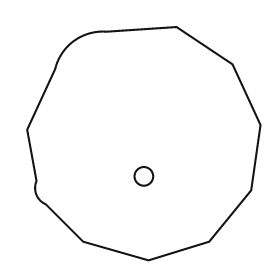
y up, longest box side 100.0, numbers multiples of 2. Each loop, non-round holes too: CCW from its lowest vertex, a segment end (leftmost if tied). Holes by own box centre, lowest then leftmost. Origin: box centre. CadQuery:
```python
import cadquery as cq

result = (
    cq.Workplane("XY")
    .moveTo(2.0, -50.0)
    .lineTo(28.0, -42.0)
    .lineTo(46.0, -20.0)
    .lineTo(50.0, 8.0)
    .lineTo(38.0, 34.0)
    .lineTo(14.0, 50.0)
    .lineTo(-16.0, 48.0)
    .threePointArc((-30.0, 44.0), (-38.0, 32.0))
    .lineTo(-50.0, 6.0)
    .lineTo(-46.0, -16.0)
    .threePointArc((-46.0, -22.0), (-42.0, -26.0))
    .lineTo(-26.0, -42.0)
    .close()
    .moveTo(0.0, -14.0)
    .circle(4.0)
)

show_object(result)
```